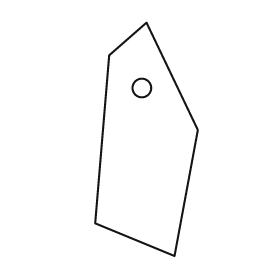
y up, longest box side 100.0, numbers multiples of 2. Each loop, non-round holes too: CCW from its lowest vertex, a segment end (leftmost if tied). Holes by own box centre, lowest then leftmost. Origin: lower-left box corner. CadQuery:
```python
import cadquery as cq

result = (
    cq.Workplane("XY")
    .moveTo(34.0, 0.0)
    .lineTo(44.0, 54.0)
    .lineTo(22.0, 100.0)
    .lineTo(6.0, 86.0)
    .lineTo(0.0, 14.0)
    .close()
    .moveTo(20.0, 72.0)
    .circle(4.0)
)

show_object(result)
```